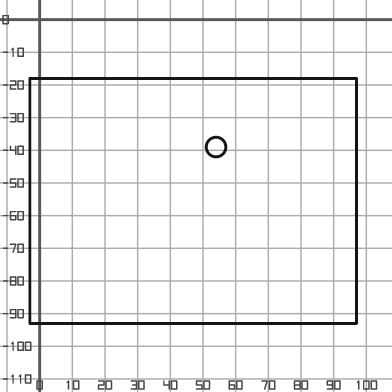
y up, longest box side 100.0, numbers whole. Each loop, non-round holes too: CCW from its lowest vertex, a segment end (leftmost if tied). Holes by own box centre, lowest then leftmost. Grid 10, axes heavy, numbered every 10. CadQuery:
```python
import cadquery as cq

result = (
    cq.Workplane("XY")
    .moveTo(-3.0, -93.0)
    .lineTo(97.0, -93.0)
    .lineTo(97.0, -18.0)
    .lineTo(-3.0, -18.0)
    .close()
    .moveTo(54.0, -39.0)
    .circle(3.0)
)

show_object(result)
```